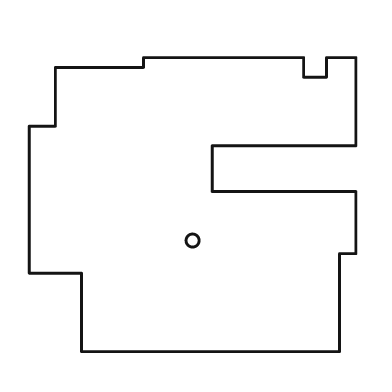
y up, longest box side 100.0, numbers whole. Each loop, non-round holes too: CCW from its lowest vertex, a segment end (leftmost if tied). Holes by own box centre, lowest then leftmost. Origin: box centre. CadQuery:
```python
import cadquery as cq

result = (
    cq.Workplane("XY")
    .moveTo(-34.0, -45.0)
    .lineTo(45.0, -45.0)
    .lineTo(45.0, -15.0)
    .lineTo(50.0, -15.0)
    .lineTo(50.0, 4.0)
    .lineTo(6.0, 4.0)
    .lineTo(6.0, 18.0)
    .lineTo(50.0, 18.0)
    .lineTo(50.0, 45.0)
    .lineTo(41.0, 45.0)
    .lineTo(41.0, 39.0)
    .lineTo(34.0, 39.0)
    .lineTo(34.0, 45.0)
    .lineTo(-15.0, 45.0)
    .lineTo(-15.0, 42.0)
    .lineTo(-42.0, 42.0)
    .lineTo(-42.0, 24.0)
    .lineTo(-50.0, 24.0)
    .lineTo(-50.0, -21.0)
    .lineTo(-34.0, -21.0)
    .close()
    .moveTo(0.0, -11.0)
    .circle(2.0)
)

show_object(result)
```